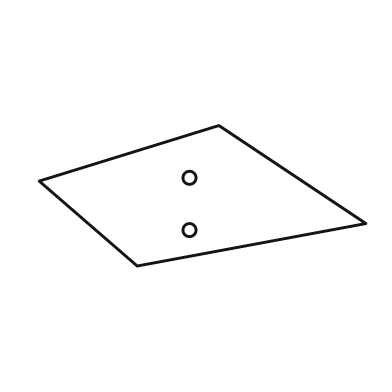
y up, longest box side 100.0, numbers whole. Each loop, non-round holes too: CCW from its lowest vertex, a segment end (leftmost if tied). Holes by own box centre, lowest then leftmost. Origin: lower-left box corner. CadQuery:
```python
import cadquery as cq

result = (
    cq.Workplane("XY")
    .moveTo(30.0, 0.0)
    .lineTo(100.0, 13.0)
    .lineTo(55.0, 43.0)
    .lineTo(0.0, 26.0)
    .close()
    .moveTo(46.0, 11.0)
    .circle(2.0)
    .moveTo(46.0, 27.0)
    .circle(2.0)
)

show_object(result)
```